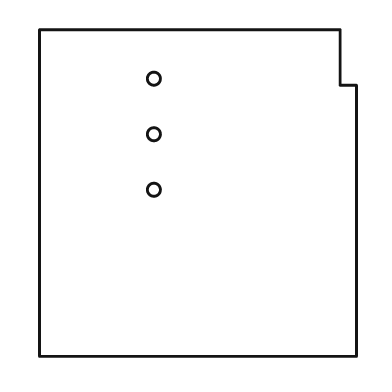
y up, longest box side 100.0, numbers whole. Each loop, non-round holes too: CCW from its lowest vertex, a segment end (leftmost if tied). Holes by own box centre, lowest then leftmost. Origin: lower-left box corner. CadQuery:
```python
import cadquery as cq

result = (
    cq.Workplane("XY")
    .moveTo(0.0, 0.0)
    .lineTo(97.0, 0.0)
    .lineTo(97.0, 83.0)
    .lineTo(92.0, 83.0)
    .lineTo(92.0, 100.0)
    .lineTo(0.0, 100.0)
    .close()
    .moveTo(35.0, 51.0)
    .circle(2.0)
    .moveTo(35.0, 68.0)
    .circle(2.0)
    .moveTo(35.0, 85.0)
    .circle(2.0)
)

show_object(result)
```